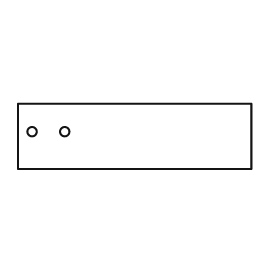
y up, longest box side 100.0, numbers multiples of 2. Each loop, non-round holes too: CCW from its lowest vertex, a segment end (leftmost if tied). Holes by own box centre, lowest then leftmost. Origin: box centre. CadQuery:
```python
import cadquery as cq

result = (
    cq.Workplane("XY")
    .moveTo(-50.0, -14.0)
    .lineTo(50.0, -14.0)
    .lineTo(50.0, 14.0)
    .lineTo(-50.0, 14.0)
    .close()
    .moveTo(-44.0, 2.0)
    .circle(2.0)
    .moveTo(-30.0, 2.0)
    .circle(2.0)
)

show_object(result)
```